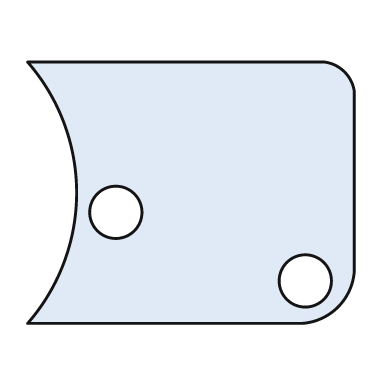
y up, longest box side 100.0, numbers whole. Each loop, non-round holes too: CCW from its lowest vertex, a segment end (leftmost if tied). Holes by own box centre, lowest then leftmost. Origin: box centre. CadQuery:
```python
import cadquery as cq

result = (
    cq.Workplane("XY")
    .moveTo(-50.0, -40.0)
    .lineTo(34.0, -40.0)
    .threePointArc((45.0, -35.0), (50.0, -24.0))
    .lineTo(50.0, 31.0)
    .threePointArc((47.0, 37.0), (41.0, 40.0))
    .lineTo(-50.0, 40.0)
    .threePointArc((-35.0, 0.0), (-50.0, -40.0))
    .close()
    .moveTo(35.0, -27.0)
    .circle(8.0)
    .moveTo(-23.0, -6.0)
    .circle(8.0)
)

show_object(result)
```